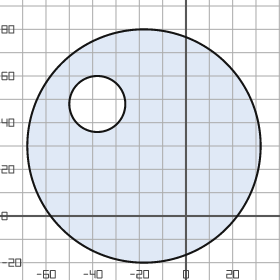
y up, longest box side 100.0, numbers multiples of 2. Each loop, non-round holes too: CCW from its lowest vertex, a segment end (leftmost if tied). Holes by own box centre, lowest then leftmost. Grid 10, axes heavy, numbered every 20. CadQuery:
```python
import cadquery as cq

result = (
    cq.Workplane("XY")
    .moveTo(-18.0, 30.0)
    .circle(50.0)
    .moveTo(-38.0, 48.0)
    .circle(12.0)
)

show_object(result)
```